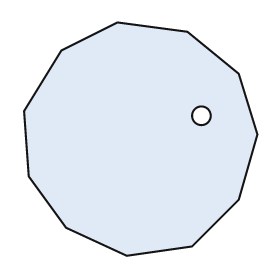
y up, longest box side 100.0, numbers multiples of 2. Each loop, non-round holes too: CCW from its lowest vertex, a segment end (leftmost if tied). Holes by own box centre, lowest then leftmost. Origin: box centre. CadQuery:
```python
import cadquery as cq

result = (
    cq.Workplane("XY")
    .moveTo(-6.0, -50.0)
    .lineTo(22.0, -46.0)
    .lineTo(42.0, -26.0)
    .lineTo(50.0, 2.0)
    .lineTo(42.0, 28.0)
    .lineTo(20.0, 46.0)
    .lineTo(-10.0, 50.0)
    .lineTo(-34.0, 38.0)
    .lineTo(-50.0, 12.0)
    .lineTo(-48.0, -16.0)
    .lineTo(-32.0, -38.0)
    .close()
    .moveTo(26.0, 10.0)
    .circle(4.0)
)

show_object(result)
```